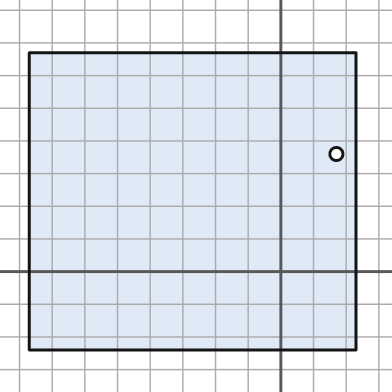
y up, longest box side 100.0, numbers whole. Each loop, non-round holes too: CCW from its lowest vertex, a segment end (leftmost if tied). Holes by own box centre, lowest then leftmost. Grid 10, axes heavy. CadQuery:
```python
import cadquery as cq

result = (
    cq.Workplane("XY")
    .moveTo(-77.0, -24.0)
    .lineTo(23.0, -24.0)
    .lineTo(23.0, 67.0)
    .lineTo(-77.0, 67.0)
    .close()
    .moveTo(17.0, 36.0)
    .circle(2.0)
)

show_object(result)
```